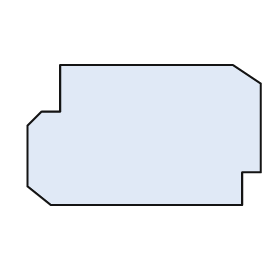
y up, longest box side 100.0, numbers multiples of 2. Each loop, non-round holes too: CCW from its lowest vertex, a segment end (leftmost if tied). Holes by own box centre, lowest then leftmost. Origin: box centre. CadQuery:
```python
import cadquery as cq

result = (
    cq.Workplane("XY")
    .moveTo(-40.0, -30.0)
    .lineTo(42.0, -30.0)
    .lineTo(42.0, -16.0)
    .lineTo(50.0, -16.0)
    .lineTo(50.0, 22.0)
    .lineTo(38.0, 30.0)
    .lineTo(-36.0, 30.0)
    .lineTo(-36.0, 10.0)
    .lineTo(-44.0, 10.0)
    .lineTo(-50.0, 4.0)
    .lineTo(-50.0, -22.0)
    .close()
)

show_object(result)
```